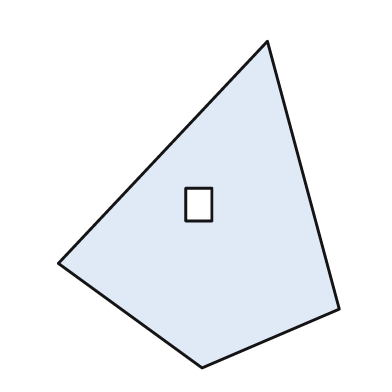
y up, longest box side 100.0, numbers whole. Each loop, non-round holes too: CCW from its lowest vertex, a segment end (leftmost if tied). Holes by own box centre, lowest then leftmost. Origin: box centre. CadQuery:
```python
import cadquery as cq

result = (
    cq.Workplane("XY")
    .moveTo(1.0, -50.0)
    .lineTo(43.0, -32.0)
    .lineTo(21.0, 50.0)
    .lineTo(-43.0, -18.0)
    .close()
    .moveTo(-4.0, -5.0)
    .lineTo(4.0, -5.0)
    .lineTo(4.0, 5.0)
    .lineTo(-4.0, 5.0)
    .close()
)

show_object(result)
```